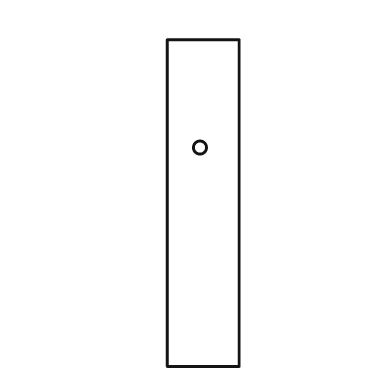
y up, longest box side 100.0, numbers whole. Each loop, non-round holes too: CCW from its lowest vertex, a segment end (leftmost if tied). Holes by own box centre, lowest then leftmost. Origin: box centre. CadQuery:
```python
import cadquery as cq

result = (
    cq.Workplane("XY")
    .moveTo(-11.0, -50.0)
    .lineTo(11.0, -50.0)
    .lineTo(11.0, 50.0)
    .lineTo(-11.0, 50.0)
    .close()
    .moveTo(-1.0, 17.0)
    .circle(2.0)
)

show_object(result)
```